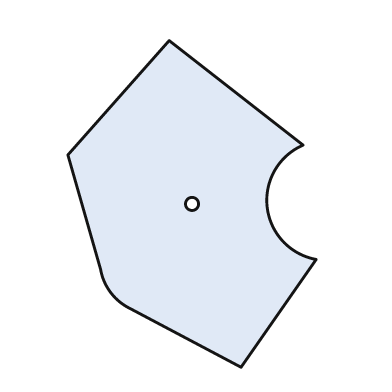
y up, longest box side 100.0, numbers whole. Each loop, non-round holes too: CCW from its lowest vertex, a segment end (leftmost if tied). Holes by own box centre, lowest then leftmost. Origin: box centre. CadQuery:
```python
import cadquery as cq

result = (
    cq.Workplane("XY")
    .moveTo(15.0, -50.0)
    .lineTo(38.0, -17.0)
    .threePointArc((23.0, -1.0), (34.0, 18.0))
    .lineTo(-7.0, 50.0)
    .lineTo(-38.0, 15.0)
    .lineTo(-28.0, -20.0)
    .threePointArc((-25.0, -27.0), (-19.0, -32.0))
    .close()
    .moveTo(0.0, 0.0)
    .circle(2.0)
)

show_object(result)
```